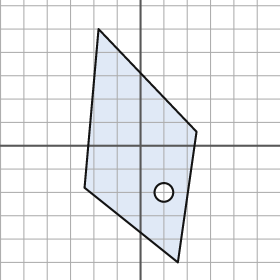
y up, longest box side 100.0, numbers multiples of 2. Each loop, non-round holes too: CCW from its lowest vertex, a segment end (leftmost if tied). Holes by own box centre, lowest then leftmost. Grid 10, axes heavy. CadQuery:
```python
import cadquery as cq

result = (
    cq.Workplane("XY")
    .moveTo(16.0, -50.0)
    .lineTo(24.0, 6.0)
    .lineTo(-18.0, 50.0)
    .lineTo(-24.0, -18.0)
    .close()
    .moveTo(10.0, -20.0)
    .circle(4.0)
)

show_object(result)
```